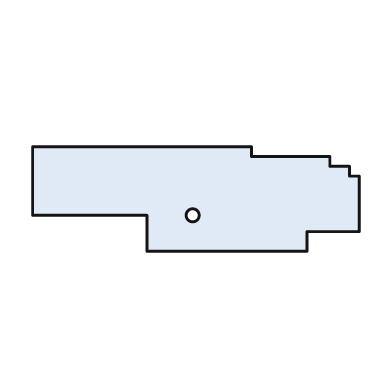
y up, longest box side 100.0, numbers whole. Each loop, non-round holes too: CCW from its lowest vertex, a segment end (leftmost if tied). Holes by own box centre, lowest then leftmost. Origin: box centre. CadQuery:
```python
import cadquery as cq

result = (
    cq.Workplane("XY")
    .moveTo(-15.0, -16.0)
    .lineTo(34.0, -16.0)
    .lineTo(34.0, -10.0)
    .lineTo(50.0, -10.0)
    .lineTo(50.0, 7.0)
    .lineTo(47.0, 7.0)
    .lineTo(47.0, 10.0)
    .lineTo(41.0, 10.0)
    .lineTo(41.0, 13.0)
    .lineTo(17.0, 13.0)
    .lineTo(17.0, 16.0)
    .lineTo(-50.0, 16.0)
    .lineTo(-50.0, -5.0)
    .lineTo(-15.0, -5.0)
    .close()
    .moveTo(-1.0, -5.0)
    .circle(2.0)
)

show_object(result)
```